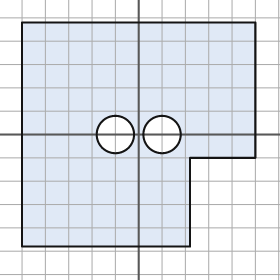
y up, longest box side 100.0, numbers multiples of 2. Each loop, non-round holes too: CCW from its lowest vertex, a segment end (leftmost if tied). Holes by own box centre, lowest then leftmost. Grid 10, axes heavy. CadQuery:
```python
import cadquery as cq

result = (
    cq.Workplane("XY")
    .moveTo(-50.0, -48.0)
    .lineTo(22.0, -48.0)
    .lineTo(22.0, -10.0)
    .lineTo(50.0, -10.0)
    .lineTo(50.0, 48.0)
    .lineTo(-50.0, 48.0)
    .close()
    .moveTo(-10.0, 0.0)
    .circle(8.0)
    .moveTo(10.0, 0.0)
    .circle(8.0)
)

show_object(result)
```